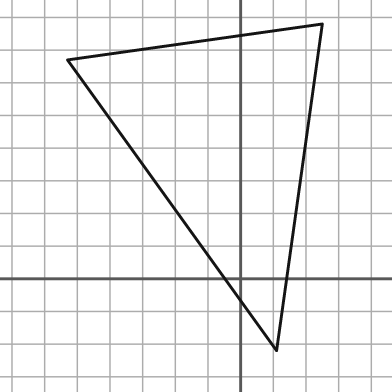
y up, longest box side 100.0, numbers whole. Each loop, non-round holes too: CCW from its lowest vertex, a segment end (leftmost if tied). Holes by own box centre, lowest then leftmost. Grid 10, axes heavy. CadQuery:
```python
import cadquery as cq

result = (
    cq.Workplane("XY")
    .moveTo(11.0, -22.0)
    .lineTo(25.0, 78.0)
    .lineTo(-53.0, 67.0)
    .close()
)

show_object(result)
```